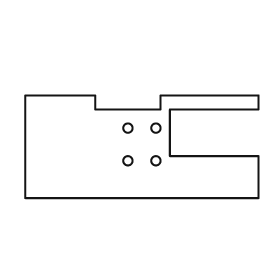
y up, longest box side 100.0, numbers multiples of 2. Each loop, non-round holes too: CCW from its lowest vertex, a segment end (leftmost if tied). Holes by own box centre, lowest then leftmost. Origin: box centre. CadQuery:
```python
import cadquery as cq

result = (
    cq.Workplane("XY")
    .moveTo(-50.0, -22.0)
    .lineTo(50.0, -22.0)
    .lineTo(50.0, -4.0)
    .lineTo(12.0, -4.0)
    .lineTo(12.0, 16.0)
    .lineTo(50.0, 16.0)
    .lineTo(50.0, 22.0)
    .lineTo(8.0, 22.0)
    .lineTo(8.0, 16.0)
    .lineTo(-20.0, 16.0)
    .lineTo(-20.0, 22.0)
    .lineTo(-50.0, 22.0)
    .close()
    .moveTo(-6.0, -6.0)
    .circle(2.0)
    .moveTo(6.0, -6.0)
    .circle(2.0)
    .moveTo(-6.0, 8.0)
    .circle(2.0)
    .moveTo(6.0, 8.0)
    .circle(2.0)
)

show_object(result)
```